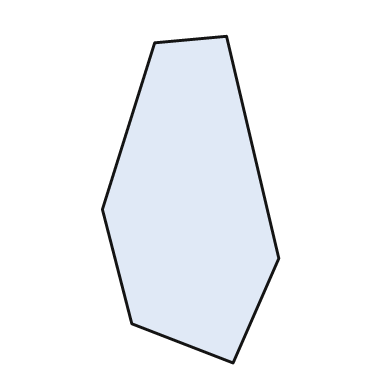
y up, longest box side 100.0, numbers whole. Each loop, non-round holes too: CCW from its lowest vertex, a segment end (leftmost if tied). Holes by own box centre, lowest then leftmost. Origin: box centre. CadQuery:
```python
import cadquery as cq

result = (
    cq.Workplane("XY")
    .moveTo(13.0, -50.0)
    .lineTo(27.0, -18.0)
    .lineTo(11.0, 50.0)
    .lineTo(-11.0, 48.0)
    .lineTo(-27.0, -3.0)
    .lineTo(-18.0, -38.0)
    .close()
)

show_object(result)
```